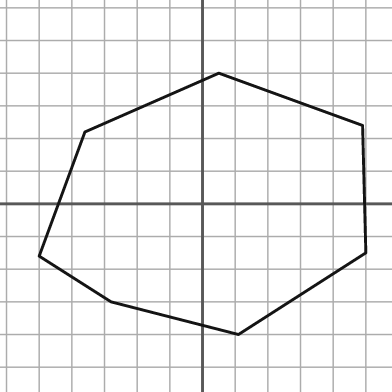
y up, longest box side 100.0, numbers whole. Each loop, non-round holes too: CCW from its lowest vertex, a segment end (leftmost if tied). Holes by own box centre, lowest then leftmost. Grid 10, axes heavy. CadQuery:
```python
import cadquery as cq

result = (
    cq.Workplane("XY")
    .moveTo(11.0, -40.0)
    .lineTo(50.0, -15.0)
    .lineTo(49.0, 24.0)
    .lineTo(5.0, 40.0)
    .lineTo(-36.0, 22.0)
    .lineTo(-50.0, -16.0)
    .lineTo(-28.0, -30.0)
    .close()
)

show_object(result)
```